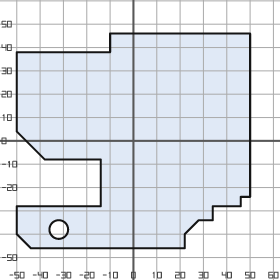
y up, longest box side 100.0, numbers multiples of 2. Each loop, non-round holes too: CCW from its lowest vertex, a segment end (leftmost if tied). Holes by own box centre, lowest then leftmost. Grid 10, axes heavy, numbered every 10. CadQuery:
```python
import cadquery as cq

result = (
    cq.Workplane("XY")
    .moveTo(-44.0, -46.0)
    .lineTo(22.0, -46.0)
    .lineTo(22.0, -40.0)
    .lineTo(28.0, -34.0)
    .lineTo(34.0, -34.0)
    .lineTo(34.0, -28.0)
    .lineTo(46.0, -28.0)
    .lineTo(46.0, -24.0)
    .lineTo(50.0, -24.0)
    .lineTo(50.0, 46.0)
    .lineTo(-10.0, 46.0)
    .lineTo(-10.0, 38.0)
    .lineTo(-50.0, 38.0)
    .lineTo(-50.0, 4.0)
    .lineTo(-38.0, -8.0)
    .lineTo(-14.0, -8.0)
    .lineTo(-14.0, -28.0)
    .lineTo(-50.0, -28.0)
    .lineTo(-50.0, -40.0)
    .close()
    .moveTo(-32.0, -38.0)
    .circle(4.0)
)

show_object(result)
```